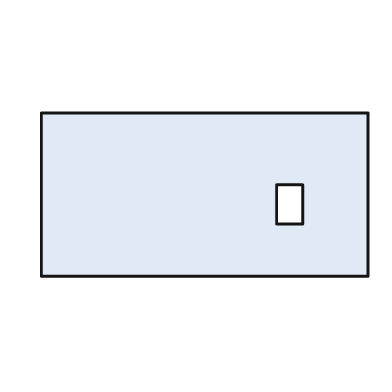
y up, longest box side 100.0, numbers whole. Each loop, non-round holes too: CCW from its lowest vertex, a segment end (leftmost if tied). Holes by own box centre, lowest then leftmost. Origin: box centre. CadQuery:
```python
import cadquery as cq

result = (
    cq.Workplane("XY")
    .moveTo(-50.0, -25.0)
    .lineTo(50.0, -25.0)
    .lineTo(50.0, 25.0)
    .lineTo(-50.0, 25.0)
    .close()
    .moveTo(22.0, -9.0)
    .lineTo(30.0, -9.0)
    .lineTo(30.0, 3.0)
    .lineTo(22.0, 3.0)
    .close()
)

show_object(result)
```